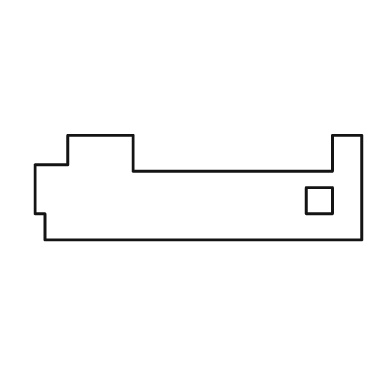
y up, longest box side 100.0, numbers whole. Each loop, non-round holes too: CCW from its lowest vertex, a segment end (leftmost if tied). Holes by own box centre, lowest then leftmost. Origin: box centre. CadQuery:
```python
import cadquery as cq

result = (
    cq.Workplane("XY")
    .moveTo(-47.0, -16.0)
    .lineTo(50.0, -16.0)
    .lineTo(50.0, 16.0)
    .lineTo(41.0, 16.0)
    .lineTo(41.0, 5.0)
    .lineTo(-20.0, 5.0)
    .lineTo(-20.0, 16.0)
    .lineTo(-40.0, 16.0)
    .lineTo(-40.0, 7.0)
    .lineTo(-50.0, 7.0)
    .lineTo(-50.0, -8.0)
    .lineTo(-47.0, -8.0)
    .close()
    .moveTo(33.0, -8.0)
    .lineTo(41.0, -8.0)
    .lineTo(41.0, 0.0)
    .lineTo(33.0, 0.0)
    .close()
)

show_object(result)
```